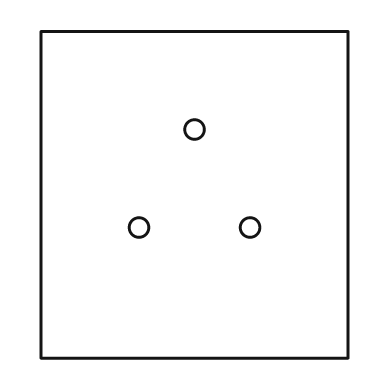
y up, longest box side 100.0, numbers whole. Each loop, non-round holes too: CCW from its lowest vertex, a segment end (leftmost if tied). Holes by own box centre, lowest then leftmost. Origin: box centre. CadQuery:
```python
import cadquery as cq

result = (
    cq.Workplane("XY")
    .moveTo(-47.0, -50.0)
    .lineTo(47.0, -50.0)
    .lineTo(47.0, 50.0)
    .lineTo(-47.0, 50.0)
    .close()
    .moveTo(-17.0, -10.0)
    .circle(3.0)
    .moveTo(17.0, -10.0)
    .circle(3.0)
    .moveTo(0.0, 20.0)
    .circle(3.0)
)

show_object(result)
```